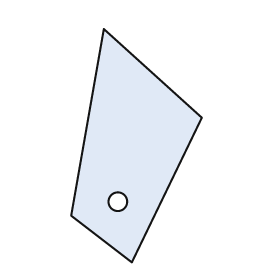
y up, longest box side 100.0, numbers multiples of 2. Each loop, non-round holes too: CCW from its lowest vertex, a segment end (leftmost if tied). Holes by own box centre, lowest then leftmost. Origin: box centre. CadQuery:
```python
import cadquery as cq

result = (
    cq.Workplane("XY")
    .moveTo(-2.0, -50.0)
    .lineTo(28.0, 12.0)
    .lineTo(-14.0, 50.0)
    .lineTo(-28.0, -30.0)
    .close()
    .moveTo(-8.0, -24.0)
    .circle(4.0)
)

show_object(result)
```